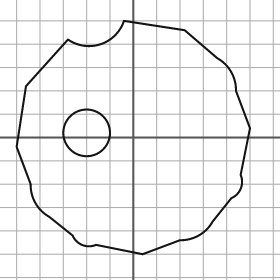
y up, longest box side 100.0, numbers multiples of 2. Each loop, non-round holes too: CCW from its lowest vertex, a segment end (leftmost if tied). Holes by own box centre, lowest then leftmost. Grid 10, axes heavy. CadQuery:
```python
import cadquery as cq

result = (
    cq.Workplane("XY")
    .moveTo(4.0, -50.0)
    .lineTo(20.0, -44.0)
    .threePointArc((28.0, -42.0), (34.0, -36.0))
    .lineTo(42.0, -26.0)
    .threePointArc((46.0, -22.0), (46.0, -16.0))
    .lineTo(50.0, 4.0)
    .lineTo(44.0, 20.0)
    .threePointArc((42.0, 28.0), (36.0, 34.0))
    .lineTo(22.0, 46.0)
    .lineTo(-4.0, 50.0)
    .threePointArc((-14.0, 40.0), (-28.0, 42.0))
    .lineTo(-46.0, 22.0)
    .lineTo(-50.0, -4.0)
    .lineTo(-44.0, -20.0)
    .threePointArc((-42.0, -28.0), (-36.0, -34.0))
    .lineTo(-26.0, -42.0)
    .threePointArc((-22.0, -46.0), (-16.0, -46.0))
    .close()
    .moveTo(-20.0, 2.0)
    .circle(10.0)
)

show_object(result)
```